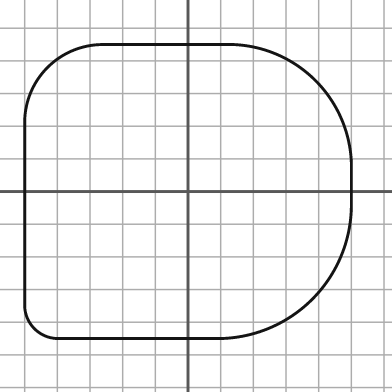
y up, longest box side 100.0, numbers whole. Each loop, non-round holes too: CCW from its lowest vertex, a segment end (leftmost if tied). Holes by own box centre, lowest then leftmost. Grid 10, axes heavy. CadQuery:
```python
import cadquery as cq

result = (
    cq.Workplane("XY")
    .moveTo(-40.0, -45.0)
    .lineTo(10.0, -45.0)
    .threePointArc((38.0, -33.0), (50.0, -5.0))
    .lineTo(50.0, 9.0)
    .threePointArc((39.0, 34.0), (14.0, 45.0))
    .lineTo(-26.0, 45.0)
    .threePointArc((-43.0, 38.0), (-50.0, 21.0))
    .lineTo(-50.0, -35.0)
    .threePointArc((-47.0, -42.0), (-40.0, -45.0))
    .close()
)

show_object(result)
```